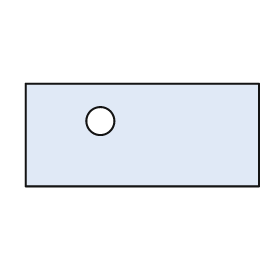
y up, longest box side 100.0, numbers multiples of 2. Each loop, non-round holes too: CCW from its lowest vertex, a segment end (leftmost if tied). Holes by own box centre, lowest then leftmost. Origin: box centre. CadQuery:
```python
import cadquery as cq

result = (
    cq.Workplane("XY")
    .moveTo(-50.0, -22.0)
    .lineTo(50.0, -22.0)
    .lineTo(50.0, 22.0)
    .lineTo(-50.0, 22.0)
    .close()
    .moveTo(-18.0, 6.0)
    .circle(6.0)
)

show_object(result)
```